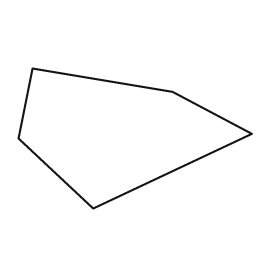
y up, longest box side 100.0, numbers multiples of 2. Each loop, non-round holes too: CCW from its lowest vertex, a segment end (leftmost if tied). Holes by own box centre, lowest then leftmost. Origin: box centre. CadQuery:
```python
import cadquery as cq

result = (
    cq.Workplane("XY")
    .moveTo(-18.0, -30.0)
    .lineTo(50.0, 2.0)
    .lineTo(16.0, 20.0)
    .lineTo(-44.0, 30.0)
    .lineTo(-50.0, 0.0)
    .close()
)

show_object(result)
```